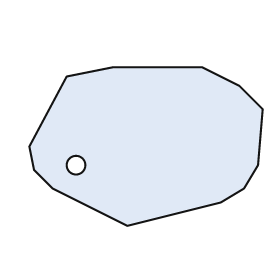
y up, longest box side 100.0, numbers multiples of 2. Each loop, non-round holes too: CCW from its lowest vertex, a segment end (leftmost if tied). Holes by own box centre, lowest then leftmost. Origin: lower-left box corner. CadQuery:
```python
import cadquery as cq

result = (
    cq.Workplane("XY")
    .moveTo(42.0, 0.0)
    .lineTo(82.0, 10.0)
    .lineTo(92.0, 16.0)
    .lineTo(98.0, 26.0)
    .lineTo(100.0, 50.0)
    .lineTo(90.0, 60.0)
    .lineTo(74.0, 68.0)
    .lineTo(36.0, 68.0)
    .lineTo(16.0, 64.0)
    .lineTo(0.0, 34.0)
    .lineTo(2.0, 24.0)
    .lineTo(10.0, 16.0)
    .close()
    .moveTo(20.0, 26.0)
    .circle(4.0)
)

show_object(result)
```